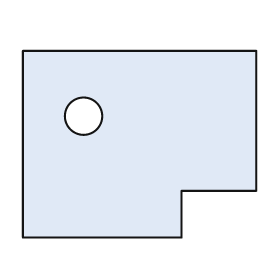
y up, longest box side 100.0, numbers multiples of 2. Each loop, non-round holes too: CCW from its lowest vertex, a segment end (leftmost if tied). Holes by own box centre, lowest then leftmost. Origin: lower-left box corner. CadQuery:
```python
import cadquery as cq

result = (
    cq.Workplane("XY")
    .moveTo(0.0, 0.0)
    .lineTo(68.0, 0.0)
    .lineTo(68.0, 20.0)
    .lineTo(100.0, 20.0)
    .lineTo(100.0, 80.0)
    .lineTo(0.0, 80.0)
    .close()
    .moveTo(26.0, 52.0)
    .circle(8.0)
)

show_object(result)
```